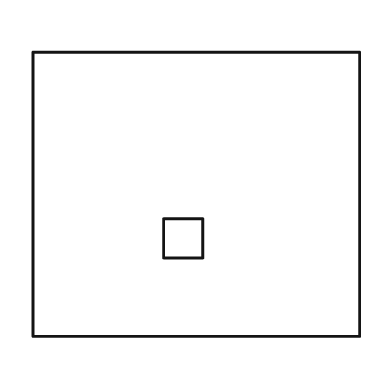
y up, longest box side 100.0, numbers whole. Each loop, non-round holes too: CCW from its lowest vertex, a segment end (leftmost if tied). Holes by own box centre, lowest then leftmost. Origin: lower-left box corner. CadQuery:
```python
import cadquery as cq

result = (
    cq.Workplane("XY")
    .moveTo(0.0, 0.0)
    .lineTo(100.0, 0.0)
    .lineTo(100.0, 87.0)
    .lineTo(0.0, 87.0)
    .close()
    .moveTo(40.0, 24.0)
    .lineTo(52.0, 24.0)
    .lineTo(52.0, 36.0)
    .lineTo(40.0, 36.0)
    .close()
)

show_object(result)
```